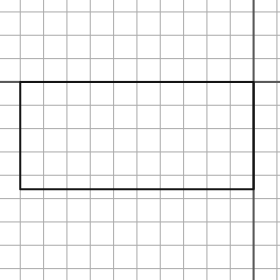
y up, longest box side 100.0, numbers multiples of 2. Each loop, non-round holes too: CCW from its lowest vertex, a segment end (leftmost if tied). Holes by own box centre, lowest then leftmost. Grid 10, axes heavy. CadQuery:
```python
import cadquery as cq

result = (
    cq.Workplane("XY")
    .moveTo(-100.0, -46.0)
    .lineTo(0.0, -46.0)
    .lineTo(0.0, 0.0)
    .lineTo(-100.0, 0.0)
    .close()
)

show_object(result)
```